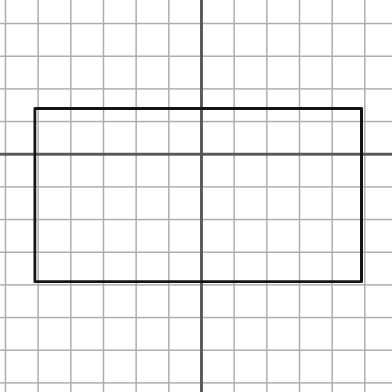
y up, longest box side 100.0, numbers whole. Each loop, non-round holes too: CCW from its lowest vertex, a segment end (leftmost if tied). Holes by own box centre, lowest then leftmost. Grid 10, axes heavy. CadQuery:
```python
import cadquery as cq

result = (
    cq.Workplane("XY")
    .moveTo(-51.0, -39.0)
    .lineTo(49.0, -39.0)
    .lineTo(49.0, 14.0)
    .lineTo(-51.0, 14.0)
    .close()
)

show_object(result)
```